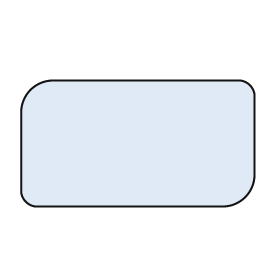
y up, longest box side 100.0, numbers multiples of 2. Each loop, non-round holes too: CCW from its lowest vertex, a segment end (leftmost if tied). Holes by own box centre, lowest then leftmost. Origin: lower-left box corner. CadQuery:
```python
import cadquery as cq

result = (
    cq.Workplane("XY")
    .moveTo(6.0, 0.0)
    .lineTo(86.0, 0.0)
    .threePointArc((96.0, 4.0), (100.0, 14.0))
    .lineTo(100.0, 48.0)
    .threePointArc((98.0, 52.0), (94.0, 54.0))
    .lineTo(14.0, 54.0)
    .threePointArc((4.0, 50.0), (0.0, 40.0))
    .lineTo(0.0, 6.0)
    .threePointArc((2.0, 2.0), (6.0, 0.0))
    .close()
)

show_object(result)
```